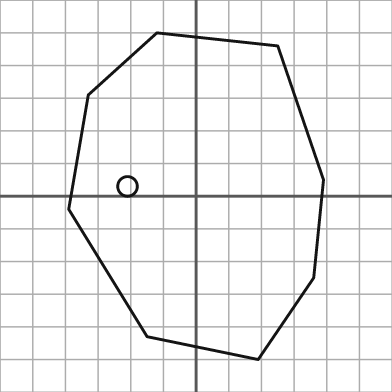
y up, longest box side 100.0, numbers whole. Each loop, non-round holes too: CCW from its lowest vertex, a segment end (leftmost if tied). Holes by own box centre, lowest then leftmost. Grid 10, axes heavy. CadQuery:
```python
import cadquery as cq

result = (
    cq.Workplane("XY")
    .moveTo(19.0, -50.0)
    .lineTo(36.0, -25.0)
    .lineTo(39.0, 5.0)
    .lineTo(25.0, 46.0)
    .lineTo(-12.0, 50.0)
    .lineTo(-33.0, 31.0)
    .lineTo(-39.0, -4.0)
    .lineTo(-15.0, -43.0)
    .close()
    .moveTo(-21.0, 3.0)
    .circle(3.0)
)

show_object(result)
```